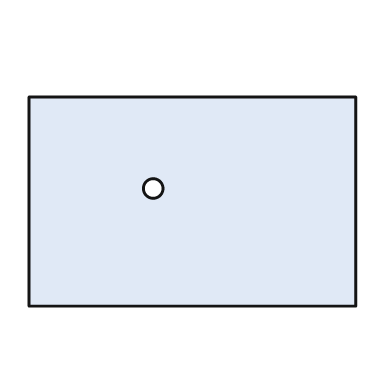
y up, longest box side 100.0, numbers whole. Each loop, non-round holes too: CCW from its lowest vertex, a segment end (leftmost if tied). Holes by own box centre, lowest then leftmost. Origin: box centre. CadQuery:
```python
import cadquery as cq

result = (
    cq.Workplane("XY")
    .moveTo(-50.0, -32.0)
    .lineTo(50.0, -32.0)
    .lineTo(50.0, 32.0)
    .lineTo(-50.0, 32.0)
    .close()
    .moveTo(-12.0, 4.0)
    .circle(3.0)
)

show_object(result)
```